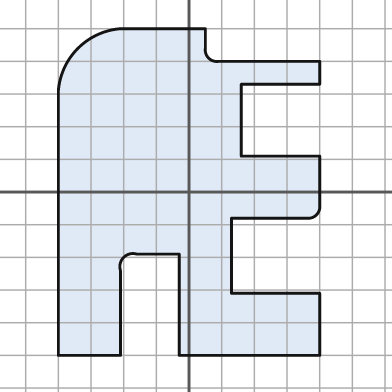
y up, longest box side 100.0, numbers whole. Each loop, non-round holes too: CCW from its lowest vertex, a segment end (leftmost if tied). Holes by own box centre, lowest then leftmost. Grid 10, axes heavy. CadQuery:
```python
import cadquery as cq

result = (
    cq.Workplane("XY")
    .moveTo(-40.0, -50.0)
    .lineTo(-21.0, -50.0)
    .lineTo(-21.0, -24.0)
    .threePointArc((-20.0, -20.0), (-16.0, -19.0))
    .lineTo(-3.0, -19.0)
    .lineTo(-3.0, -50.0)
    .lineTo(40.0, -50.0)
    .lineTo(40.0, -31.0)
    .lineTo(13.0, -31.0)
    .lineTo(13.0, -8.0)
    .lineTo(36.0, -8.0)
    .threePointArc((39.0, -7.0), (40.0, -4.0))
    .lineTo(40.0, 11.0)
    .lineTo(16.0, 11.0)
    .lineTo(16.0, 33.0)
    .lineTo(40.0, 33.0)
    .lineTo(40.0, 40.0)
    .lineTo(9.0, 40.0)
    .threePointArc((6.0, 41.0), (5.0, 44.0))
    .lineTo(5.0, 50.0)
    .lineTo(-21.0, 50.0)
    .threePointArc((-34.0, 44.0), (-40.0, 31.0))
    .close()
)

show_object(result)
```